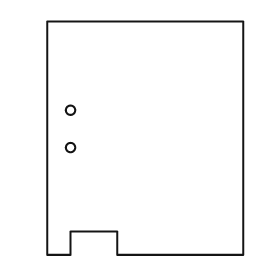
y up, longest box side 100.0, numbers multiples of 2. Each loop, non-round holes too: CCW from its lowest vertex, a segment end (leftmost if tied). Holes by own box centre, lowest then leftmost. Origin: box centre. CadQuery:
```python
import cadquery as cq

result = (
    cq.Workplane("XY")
    .moveTo(-42.0, -50.0)
    .lineTo(-32.0, -50.0)
    .lineTo(-32.0, -40.0)
    .lineTo(-12.0, -40.0)
    .lineTo(-12.0, -50.0)
    .lineTo(42.0, -50.0)
    .lineTo(42.0, 50.0)
    .lineTo(-42.0, 50.0)
    .close()
    .moveTo(-32.0, -4.0)
    .circle(2.0)
    .moveTo(-32.0, 12.0)
    .circle(2.0)
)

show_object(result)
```